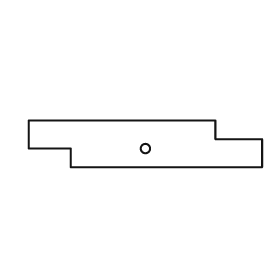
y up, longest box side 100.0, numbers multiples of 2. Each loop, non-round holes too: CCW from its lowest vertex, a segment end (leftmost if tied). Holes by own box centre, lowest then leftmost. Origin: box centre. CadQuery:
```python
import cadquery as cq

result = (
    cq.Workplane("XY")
    .moveTo(-32.0, -10.0)
    .lineTo(50.0, -10.0)
    .lineTo(50.0, 2.0)
    .lineTo(30.0, 2.0)
    .lineTo(30.0, 10.0)
    .lineTo(-50.0, 10.0)
    .lineTo(-50.0, -2.0)
    .lineTo(-32.0, -2.0)
    .close()
    .moveTo(0.0, -2.0)
    .circle(2.0)
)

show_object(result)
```